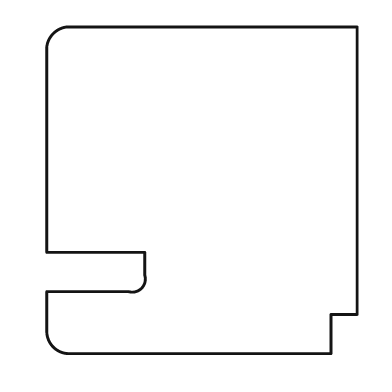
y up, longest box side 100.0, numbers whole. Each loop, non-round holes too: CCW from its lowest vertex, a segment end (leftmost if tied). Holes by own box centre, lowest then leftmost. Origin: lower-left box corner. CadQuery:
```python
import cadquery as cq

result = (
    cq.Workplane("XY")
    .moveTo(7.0, 0.0)
    .lineTo(87.0, 0.0)
    .lineTo(87.0, 12.0)
    .lineTo(95.0, 12.0)
    .lineTo(95.0, 100.0)
    .lineTo(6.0, 100.0)
    .threePointArc((2.0, 98.0), (0.0, 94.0))
    .lineTo(0.0, 31.0)
    .lineTo(30.0, 31.0)
    .lineTo(30.0, 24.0)
    .threePointArc((29.0, 20.0), (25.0, 19.0))
    .lineTo(0.0, 19.0)
    .lineTo(0.0, 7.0)
    .threePointArc((2.0, 2.0), (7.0, 0.0))
    .close()
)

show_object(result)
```